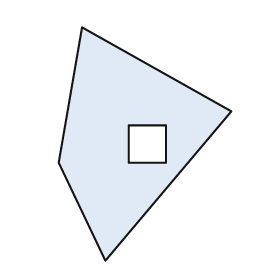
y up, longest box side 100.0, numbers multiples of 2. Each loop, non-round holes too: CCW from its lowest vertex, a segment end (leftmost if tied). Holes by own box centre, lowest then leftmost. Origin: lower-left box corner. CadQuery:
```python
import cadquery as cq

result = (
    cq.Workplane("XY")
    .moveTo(20.0, 0.0)
    .lineTo(74.0, 64.0)
    .lineTo(10.0, 100.0)
    .lineTo(0.0, 42.0)
    .close()
    .moveTo(30.0, 42.0)
    .lineTo(46.0, 42.0)
    .lineTo(46.0, 58.0)
    .lineTo(30.0, 58.0)
    .close()
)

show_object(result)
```